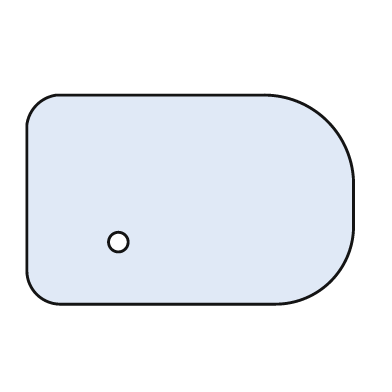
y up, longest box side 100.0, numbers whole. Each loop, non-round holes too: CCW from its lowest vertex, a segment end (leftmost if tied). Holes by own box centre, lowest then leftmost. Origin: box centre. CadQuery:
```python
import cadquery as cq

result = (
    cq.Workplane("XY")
    .moveTo(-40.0, -32.0)
    .lineTo(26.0, -32.0)
    .threePointArc((43.0, -25.0), (50.0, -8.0))
    .lineTo(50.0, 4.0)
    .threePointArc((42.0, 24.0), (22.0, 32.0))
    .lineTo(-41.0, 32.0)
    .threePointArc((-47.0, 29.0), (-50.0, 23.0))
    .lineTo(-50.0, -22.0)
    .threePointArc((-47.0, -29.0), (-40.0, -32.0))
    .close()
    .moveTo(-22.0, -13.0)
    .circle(3.0)
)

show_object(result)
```